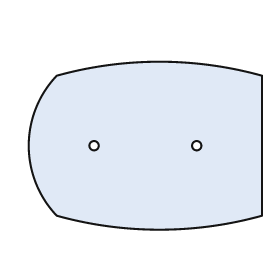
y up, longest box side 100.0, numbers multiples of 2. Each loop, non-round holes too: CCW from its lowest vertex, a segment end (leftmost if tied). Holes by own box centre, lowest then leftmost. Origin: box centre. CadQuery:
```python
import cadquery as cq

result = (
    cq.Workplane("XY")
    .moveTo(-38.0, -30.0)
    .threePointArc((6.0, -36.0), (50.0, -30.0))
    .lineTo(50.0, 30.0)
    .threePointArc((6.0, 36.0), (-38.0, 30.0))
    .threePointArc((-50.0, 0.0), (-38.0, -30.0))
    .close()
    .moveTo(-22.0, 0.0)
    .circle(2.0)
    .moveTo(22.0, 0.0)
    .circle(2.0)
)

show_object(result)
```